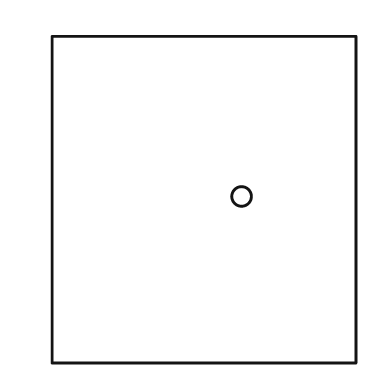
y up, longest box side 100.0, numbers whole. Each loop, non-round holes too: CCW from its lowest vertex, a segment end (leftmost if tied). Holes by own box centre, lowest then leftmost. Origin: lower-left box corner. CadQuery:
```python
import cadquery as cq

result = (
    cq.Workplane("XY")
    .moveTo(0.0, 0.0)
    .lineTo(93.0, 0.0)
    .lineTo(93.0, 100.0)
    .lineTo(0.0, 100.0)
    .close()
    .moveTo(58.0, 51.0)
    .circle(3.0)
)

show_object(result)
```